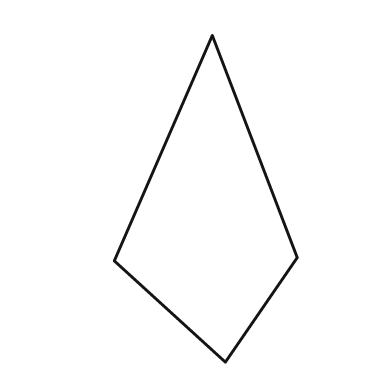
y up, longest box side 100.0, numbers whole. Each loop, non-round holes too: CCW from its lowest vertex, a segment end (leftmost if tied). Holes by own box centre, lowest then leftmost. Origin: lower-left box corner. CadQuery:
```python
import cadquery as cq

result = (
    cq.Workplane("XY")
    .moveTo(34.0, 0.0)
    .lineTo(56.0, 32.0)
    .lineTo(30.0, 100.0)
    .lineTo(0.0, 31.0)
    .close()
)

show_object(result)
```